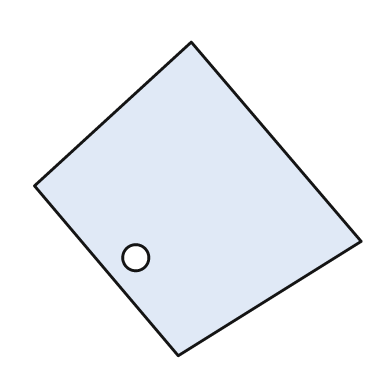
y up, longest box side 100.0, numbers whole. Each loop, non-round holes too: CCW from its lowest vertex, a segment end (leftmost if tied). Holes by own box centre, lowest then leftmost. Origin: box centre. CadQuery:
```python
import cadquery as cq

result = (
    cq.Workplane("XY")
    .moveTo(-6.0, -48.0)
    .lineTo(50.0, -13.0)
    .lineTo(-2.0, 48.0)
    .lineTo(-50.0, 4.0)
    .close()
    .moveTo(-19.0, -18.0)
    .circle(4.0)
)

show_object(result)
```